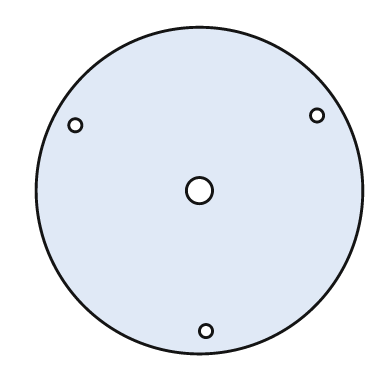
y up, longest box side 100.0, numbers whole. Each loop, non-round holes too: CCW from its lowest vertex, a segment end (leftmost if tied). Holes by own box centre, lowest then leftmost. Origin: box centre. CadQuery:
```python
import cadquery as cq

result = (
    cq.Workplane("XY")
    .moveTo(0.0, 0.0)
    .circle(50.0)
    .moveTo(2.0, -43.0)
    .circle(2.0)
    .moveTo(0.0, 0.0)
    .circle(4.0)
    .moveTo(-38.0, 20.0)
    .circle(2.0)
    .moveTo(36.0, 23.0)
    .circle(2.0)
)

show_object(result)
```